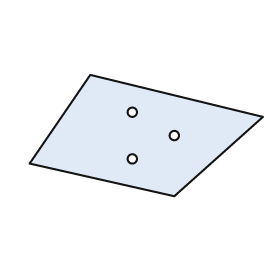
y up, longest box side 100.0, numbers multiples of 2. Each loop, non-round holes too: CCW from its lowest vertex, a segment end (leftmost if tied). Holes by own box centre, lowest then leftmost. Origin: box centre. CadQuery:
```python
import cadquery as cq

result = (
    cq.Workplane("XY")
    .moveTo(12.0, -26.0)
    .lineTo(50.0, 8.0)
    .lineTo(-24.0, 26.0)
    .lineTo(-50.0, -12.0)
    .close()
    .moveTo(-6.0, -10.0)
    .circle(2.0)
    .moveTo(12.0, 0.0)
    .circle(2.0)
    .moveTo(-6.0, 10.0)
    .circle(2.0)
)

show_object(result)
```